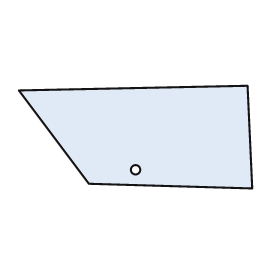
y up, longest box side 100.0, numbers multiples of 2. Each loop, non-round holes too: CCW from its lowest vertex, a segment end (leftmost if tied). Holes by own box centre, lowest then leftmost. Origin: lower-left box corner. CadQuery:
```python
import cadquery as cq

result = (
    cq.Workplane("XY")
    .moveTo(100.0, 0.0)
    .lineTo(98.0, 44.0)
    .lineTo(0.0, 42.0)
    .lineTo(30.0, 2.0)
    .close()
    .moveTo(50.0, 8.0)
    .circle(2.0)
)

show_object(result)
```